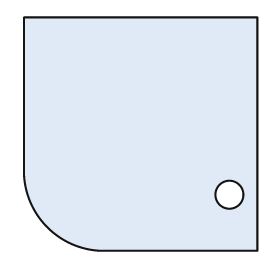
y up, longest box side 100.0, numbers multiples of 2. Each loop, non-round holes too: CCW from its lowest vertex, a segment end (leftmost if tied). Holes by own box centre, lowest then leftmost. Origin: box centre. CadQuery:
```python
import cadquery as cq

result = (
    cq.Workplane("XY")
    .moveTo(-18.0, -50.0)
    .lineTo(50.0, -50.0)
    .lineTo(50.0, 50.0)
    .lineTo(-50.0, 50.0)
    .lineTo(-50.0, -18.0)
    .threePointArc((-40.0, -40.0), (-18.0, -50.0))
    .close()
    .moveTo(38.0, -26.0)
    .circle(6.0)
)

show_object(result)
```